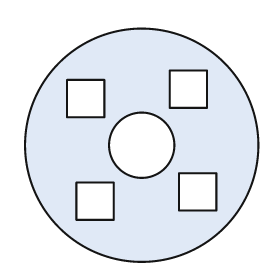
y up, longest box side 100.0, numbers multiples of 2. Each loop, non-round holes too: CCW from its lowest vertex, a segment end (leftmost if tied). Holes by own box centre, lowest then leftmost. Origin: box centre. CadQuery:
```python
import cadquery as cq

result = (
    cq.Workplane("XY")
    .moveTo(0.0, 0.0)
    .circle(50.0)
    .moveTo(-28.0, -32.0)
    .lineTo(-12.0, -32.0)
    .lineTo(-12.0, -16.0)
    .lineTo(-28.0, -16.0)
    .close()
    .moveTo(16.0, -28.0)
    .lineTo(32.0, -28.0)
    .lineTo(32.0, -12.0)
    .lineTo(16.0, -12.0)
    .close()
    .moveTo(0.0, 0.0)
    .circle(14.0)
    .moveTo(-32.0, 12.0)
    .lineTo(-16.0, 12.0)
    .lineTo(-16.0, 28.0)
    .lineTo(-32.0, 28.0)
    .close()
    .moveTo(12.0, 16.0)
    .lineTo(28.0, 16.0)
    .lineTo(28.0, 32.0)
    .lineTo(12.0, 32.0)
    .close()
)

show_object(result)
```